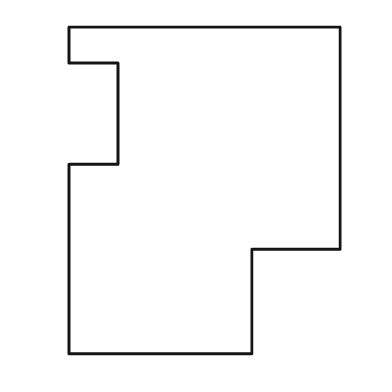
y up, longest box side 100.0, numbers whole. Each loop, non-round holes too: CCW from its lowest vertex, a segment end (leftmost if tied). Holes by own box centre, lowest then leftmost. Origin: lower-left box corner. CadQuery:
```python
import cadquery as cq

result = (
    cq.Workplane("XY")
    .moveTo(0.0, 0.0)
    .lineTo(56.0, 0.0)
    .lineTo(56.0, 32.0)
    .lineTo(83.0, 32.0)
    .lineTo(83.0, 100.0)
    .lineTo(0.0, 100.0)
    .lineTo(0.0, 89.0)
    .lineTo(15.0, 89.0)
    .lineTo(15.0, 58.0)
    .lineTo(0.0, 58.0)
    .close()
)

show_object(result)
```